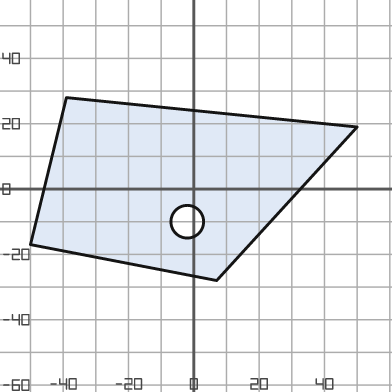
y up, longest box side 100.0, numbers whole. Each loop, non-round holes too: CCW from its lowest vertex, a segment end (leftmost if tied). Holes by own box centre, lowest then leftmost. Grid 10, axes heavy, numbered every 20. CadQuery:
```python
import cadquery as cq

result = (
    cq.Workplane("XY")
    .moveTo(7.0, -28.0)
    .lineTo(50.0, 19.0)
    .lineTo(-39.0, 28.0)
    .lineTo(-50.0, -17.0)
    .close()
    .moveTo(-2.0, -10.0)
    .circle(5.0)
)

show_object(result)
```